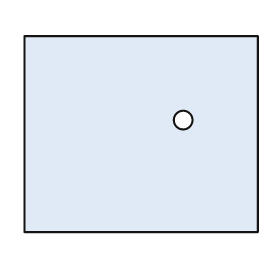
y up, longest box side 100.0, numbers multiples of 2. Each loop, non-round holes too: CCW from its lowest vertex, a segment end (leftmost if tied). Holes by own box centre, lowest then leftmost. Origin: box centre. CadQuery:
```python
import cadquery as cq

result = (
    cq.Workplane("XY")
    .moveTo(-50.0, -42.0)
    .lineTo(50.0, -42.0)
    .lineTo(50.0, 42.0)
    .lineTo(-50.0, 42.0)
    .close()
    .moveTo(18.0, 6.0)
    .circle(4.0)
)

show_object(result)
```